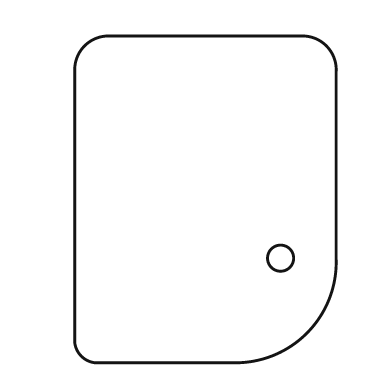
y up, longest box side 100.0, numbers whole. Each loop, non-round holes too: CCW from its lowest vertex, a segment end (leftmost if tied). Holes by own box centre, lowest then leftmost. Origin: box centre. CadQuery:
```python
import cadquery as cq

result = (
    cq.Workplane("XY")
    .moveTo(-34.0, -50.0)
    .lineTo(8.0, -50.0)
    .threePointArc((31.0, -41.0), (40.0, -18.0))
    .lineTo(40.0, 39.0)
    .threePointArc((37.0, 47.0), (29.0, 50.0))
    .lineTo(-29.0, 50.0)
    .threePointArc((-37.0, 47.0), (-40.0, 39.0))
    .lineTo(-40.0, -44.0)
    .threePointArc((-38.0, -48.0), (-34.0, -50.0))
    .close()
    .moveTo(23.0, -18.0)
    .circle(4.0)
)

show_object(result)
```